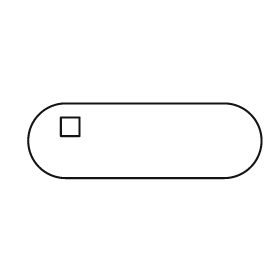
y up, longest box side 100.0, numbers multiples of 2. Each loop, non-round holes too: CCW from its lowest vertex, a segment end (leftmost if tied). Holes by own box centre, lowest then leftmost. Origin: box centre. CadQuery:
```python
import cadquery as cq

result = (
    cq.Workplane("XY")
    .moveTo(-34.0, -16.0)
    .lineTo(34.0, -16.0)
    .threePointArc((50.0, 0.0), (34.0, 16.0))
    .lineTo(-34.0, 16.0)
    .threePointArc((-50.0, 0.0), (-34.0, -16.0))
    .close()
    .moveTo(-36.0, 2.0)
    .lineTo(-28.0, 2.0)
    .lineTo(-28.0, 10.0)
    .lineTo(-36.0, 10.0)
    .close()
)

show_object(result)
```